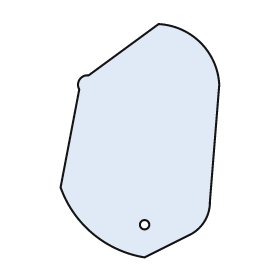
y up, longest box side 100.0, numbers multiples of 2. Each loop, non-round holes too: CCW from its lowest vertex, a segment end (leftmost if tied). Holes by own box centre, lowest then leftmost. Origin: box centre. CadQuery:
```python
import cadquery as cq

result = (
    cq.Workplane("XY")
    .moveTo(2.0, -50.0)
    .lineTo(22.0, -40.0)
    .threePointArc((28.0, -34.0), (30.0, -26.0))
    .lineTo(34.0, 24.0)
    .threePointArc((26.0, 42.0), (8.0, 50.0))
    .lineTo(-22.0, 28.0)
    .threePointArc((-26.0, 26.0), (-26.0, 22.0))
    .lineTo(-34.0, -20.0)
    .threePointArc((-20.0, -40.0), (2.0, -50.0))
    .close()
    .moveTo(2.0, -36.0)
    .circle(2.0)
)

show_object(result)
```